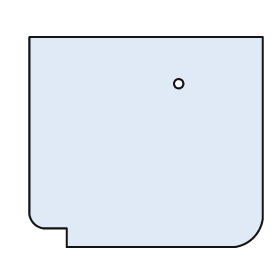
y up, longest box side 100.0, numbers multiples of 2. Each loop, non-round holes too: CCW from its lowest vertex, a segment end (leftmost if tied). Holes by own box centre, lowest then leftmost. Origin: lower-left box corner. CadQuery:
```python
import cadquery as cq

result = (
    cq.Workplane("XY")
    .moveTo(16.0, 0.0)
    .lineTo(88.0, 0.0)
    .threePointArc((96.0, 4.0), (100.0, 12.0))
    .lineTo(100.0, 90.0)
    .lineTo(0.0, 90.0)
    .lineTo(0.0, 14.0)
    .threePointArc((2.0, 10.0), (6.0, 8.0))
    .lineTo(16.0, 8.0)
    .close()
    .moveTo(64.0, 70.0)
    .circle(2.0)
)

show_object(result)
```